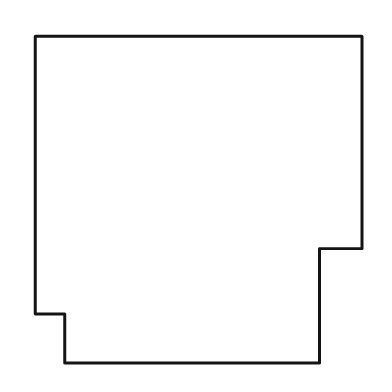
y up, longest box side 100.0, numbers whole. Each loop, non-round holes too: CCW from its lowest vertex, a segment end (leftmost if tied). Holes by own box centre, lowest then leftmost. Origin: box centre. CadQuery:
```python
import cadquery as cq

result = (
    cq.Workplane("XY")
    .moveTo(-41.0, -50.0)
    .lineTo(37.0, -50.0)
    .lineTo(37.0, -15.0)
    .lineTo(50.0, -15.0)
    .lineTo(50.0, 50.0)
    .lineTo(-50.0, 50.0)
    .lineTo(-50.0, -35.0)
    .lineTo(-41.0, -35.0)
    .close()
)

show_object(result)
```